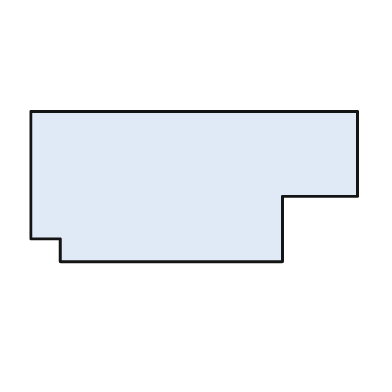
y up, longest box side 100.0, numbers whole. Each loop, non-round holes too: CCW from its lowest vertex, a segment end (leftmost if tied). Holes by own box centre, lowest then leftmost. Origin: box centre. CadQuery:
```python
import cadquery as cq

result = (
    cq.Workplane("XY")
    .moveTo(-41.0, -23.0)
    .lineTo(27.0, -23.0)
    .lineTo(27.0, -3.0)
    .lineTo(50.0, -3.0)
    .lineTo(50.0, 23.0)
    .lineTo(-50.0, 23.0)
    .lineTo(-50.0, -16.0)
    .lineTo(-41.0, -16.0)
    .close()
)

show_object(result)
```